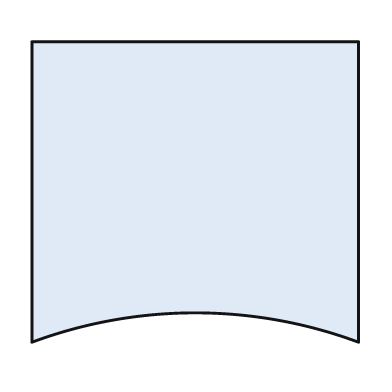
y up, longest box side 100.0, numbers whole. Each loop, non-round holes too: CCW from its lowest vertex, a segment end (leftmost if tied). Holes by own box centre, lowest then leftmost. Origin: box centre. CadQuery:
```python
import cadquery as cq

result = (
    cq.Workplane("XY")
    .moveTo(-50.0, -46.0)
    .threePointArc((0.0, -37.0), (50.0, -46.0))
    .lineTo(50.0, 46.0)
    .lineTo(-50.0, 46.0)
    .close()
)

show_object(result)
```